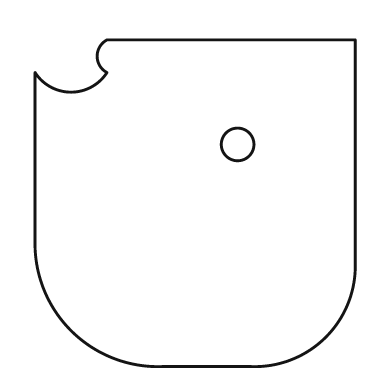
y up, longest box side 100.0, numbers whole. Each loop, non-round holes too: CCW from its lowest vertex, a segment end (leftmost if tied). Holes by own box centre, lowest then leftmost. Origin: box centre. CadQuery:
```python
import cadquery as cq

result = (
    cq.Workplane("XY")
    .moveTo(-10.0, -50.0)
    .lineTo(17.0, -50.0)
    .threePointArc((40.0, -41.0), (49.0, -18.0))
    .lineTo(49.0, 50.0)
    .lineTo(-27.0, 50.0)
    .threePointArc((-30.0, 45.0), (-27.0, 40.0))
    .threePointArc((-38.0, 34.0), (-49.0, 40.0))
    .lineTo(-49.0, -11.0)
    .threePointArc((-38.0, -39.0), (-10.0, -50.0))
    .close()
    .moveTo(13.0, 18.0)
    .circle(5.0)
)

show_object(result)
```